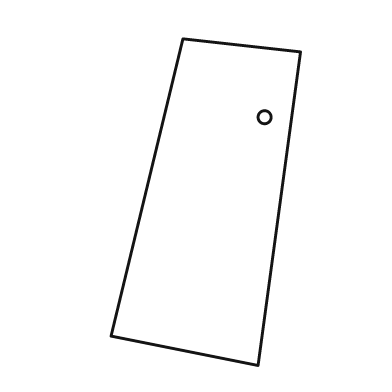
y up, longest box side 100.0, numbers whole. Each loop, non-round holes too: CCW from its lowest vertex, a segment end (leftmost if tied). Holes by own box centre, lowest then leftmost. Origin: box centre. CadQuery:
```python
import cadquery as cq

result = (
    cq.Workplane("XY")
    .moveTo(16.0, -50.0)
    .lineTo(29.0, 46.0)
    .lineTo(-7.0, 50.0)
    .lineTo(-29.0, -41.0)
    .close()
    .moveTo(18.0, 26.0)
    .circle(2.0)
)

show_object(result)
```